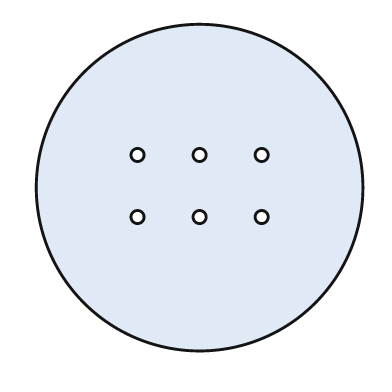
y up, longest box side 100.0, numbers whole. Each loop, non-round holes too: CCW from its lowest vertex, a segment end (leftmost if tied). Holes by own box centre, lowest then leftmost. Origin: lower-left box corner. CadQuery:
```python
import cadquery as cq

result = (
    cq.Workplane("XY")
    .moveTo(50.0, 50.0)
    .circle(50.0)
    .moveTo(31.0, 41.0)
    .circle(2.0)
    .moveTo(50.0, 41.0)
    .circle(2.0)
    .moveTo(69.0, 41.0)
    .circle(2.0)
    .moveTo(31.0, 60.0)
    .circle(2.0)
    .moveTo(50.0, 60.0)
    .circle(2.0)
    .moveTo(69.0, 60.0)
    .circle(2.0)
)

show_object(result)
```